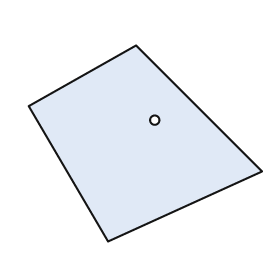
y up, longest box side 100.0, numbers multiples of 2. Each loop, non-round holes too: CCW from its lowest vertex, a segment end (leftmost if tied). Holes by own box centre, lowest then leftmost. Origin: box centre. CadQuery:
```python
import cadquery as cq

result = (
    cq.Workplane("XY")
    .moveTo(-16.0, -42.0)
    .lineTo(50.0, -12.0)
    .lineTo(-4.0, 42.0)
    .lineTo(-50.0, 16.0)
    .close()
    .moveTo(4.0, 10.0)
    .circle(2.0)
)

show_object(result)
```